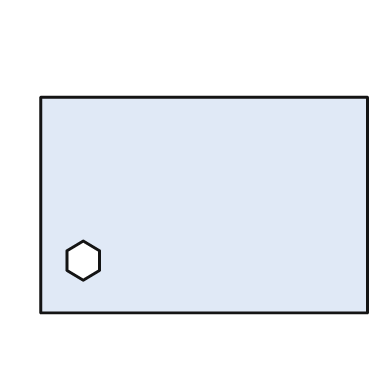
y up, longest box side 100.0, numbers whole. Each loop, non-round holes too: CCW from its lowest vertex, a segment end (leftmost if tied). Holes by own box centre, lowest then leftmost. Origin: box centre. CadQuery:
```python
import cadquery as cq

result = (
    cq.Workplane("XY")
    .moveTo(-50.0, -33.0)
    .lineTo(50.0, -33.0)
    .lineTo(50.0, 33.0)
    .lineTo(-50.0, 33.0)
    .close()
    .moveTo(-37.0, -23.0)
    .lineTo(-32.0, -20.0)
    .lineTo(-32.0, -14.0)
    .lineTo(-37.0, -11.0)
    .lineTo(-42.0, -14.0)
    .lineTo(-42.0, -20.0)
    .close()
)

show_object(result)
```